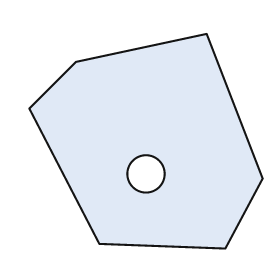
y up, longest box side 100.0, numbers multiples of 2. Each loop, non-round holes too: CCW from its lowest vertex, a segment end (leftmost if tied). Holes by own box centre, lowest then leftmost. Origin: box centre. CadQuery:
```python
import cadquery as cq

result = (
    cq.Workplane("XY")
    .moveTo(34.0, -46.0)
    .lineTo(50.0, -16.0)
    .lineTo(26.0, 46.0)
    .lineTo(-30.0, 34.0)
    .lineTo(-50.0, 14.0)
    .lineTo(-20.0, -44.0)
    .close()
    .moveTo(0.0, -14.0)
    .circle(8.0)
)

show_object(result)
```